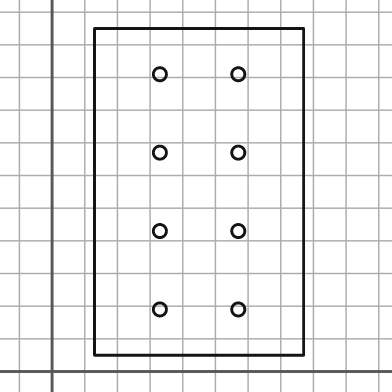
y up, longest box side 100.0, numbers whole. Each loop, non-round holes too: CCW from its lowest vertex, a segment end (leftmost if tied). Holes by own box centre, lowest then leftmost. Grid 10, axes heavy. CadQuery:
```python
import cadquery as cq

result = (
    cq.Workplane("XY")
    .moveTo(13.0, 5.0)
    .lineTo(77.0, 5.0)
    .lineTo(77.0, 105.0)
    .lineTo(13.0, 105.0)
    .close()
    .moveTo(33.0, 19.0)
    .circle(2.0)
    .moveTo(57.0, 19.0)
    .circle(2.0)
    .moveTo(33.0, 43.0)
    .circle(2.0)
    .moveTo(57.0, 43.0)
    .circle(2.0)
    .moveTo(33.0, 67.0)
    .circle(2.0)
    .moveTo(57.0, 67.0)
    .circle(2.0)
    .moveTo(33.0, 91.0)
    .circle(2.0)
    .moveTo(57.0, 91.0)
    .circle(2.0)
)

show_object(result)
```